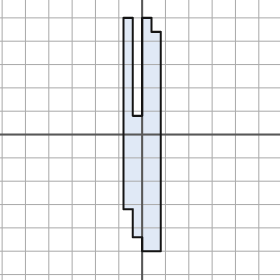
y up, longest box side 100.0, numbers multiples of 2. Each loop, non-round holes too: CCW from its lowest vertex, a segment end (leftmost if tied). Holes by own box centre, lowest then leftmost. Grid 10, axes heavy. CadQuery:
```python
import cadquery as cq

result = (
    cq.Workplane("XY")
    .moveTo(0.0, -50.0)
    .lineTo(8.0, -50.0)
    .lineTo(8.0, 44.0)
    .lineTo(4.0, 44.0)
    .lineTo(4.0, 50.0)
    .lineTo(0.0, 50.0)
    .lineTo(0.0, 8.0)
    .lineTo(-4.0, 8.0)
    .lineTo(-4.0, 50.0)
    .lineTo(-8.0, 50.0)
    .lineTo(-8.0, -32.0)
    .lineTo(-4.0, -32.0)
    .lineTo(-4.0, -44.0)
    .lineTo(0.0, -44.0)
    .close()
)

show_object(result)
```